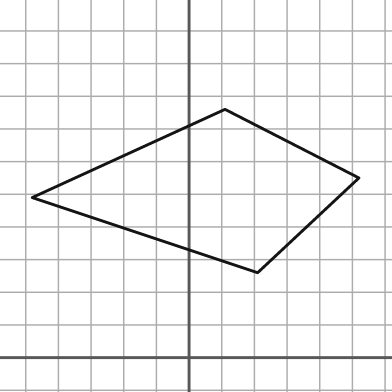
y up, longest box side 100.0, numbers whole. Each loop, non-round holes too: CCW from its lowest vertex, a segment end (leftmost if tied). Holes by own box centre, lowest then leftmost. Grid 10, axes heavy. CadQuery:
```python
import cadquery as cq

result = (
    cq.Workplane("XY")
    .moveTo(21.0, 26.0)
    .lineTo(52.0, 55.0)
    .lineTo(11.0, 76.0)
    .lineTo(-48.0, 49.0)
    .close()
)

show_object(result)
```